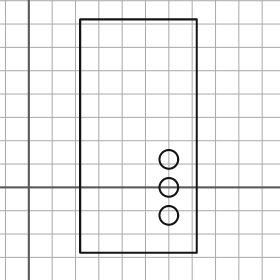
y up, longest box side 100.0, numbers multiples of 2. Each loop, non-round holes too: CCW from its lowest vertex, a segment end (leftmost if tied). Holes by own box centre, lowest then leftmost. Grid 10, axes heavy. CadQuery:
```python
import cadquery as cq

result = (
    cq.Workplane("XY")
    .moveTo(22.0, -28.0)
    .lineTo(72.0, -28.0)
    .lineTo(72.0, 72.0)
    .lineTo(22.0, 72.0)
    .close()
    .moveTo(60.0, -12.0)
    .circle(4.0)
    .moveTo(60.0, 0.0)
    .circle(4.0)
    .moveTo(60.0, 12.0)
    .circle(4.0)
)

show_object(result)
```